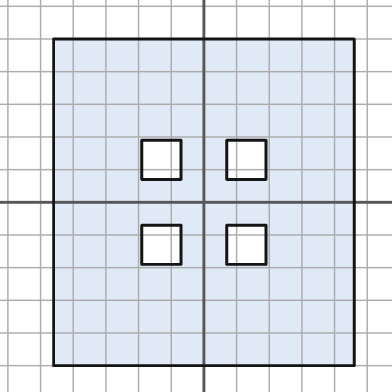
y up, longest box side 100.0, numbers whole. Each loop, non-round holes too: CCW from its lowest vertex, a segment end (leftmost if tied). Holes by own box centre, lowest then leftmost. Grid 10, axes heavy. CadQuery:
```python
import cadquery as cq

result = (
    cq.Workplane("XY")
    .moveTo(-46.0, -50.0)
    .lineTo(46.0, -50.0)
    .lineTo(46.0, 50.0)
    .lineTo(-46.0, 50.0)
    .close()
    .moveTo(-19.0, -19.0)
    .lineTo(-7.0, -19.0)
    .lineTo(-7.0, -7.0)
    .lineTo(-19.0, -7.0)
    .close()
    .moveTo(7.0, -19.0)
    .lineTo(19.0, -19.0)
    .lineTo(19.0, -7.0)
    .lineTo(7.0, -7.0)
    .close()
    .moveTo(-19.0, 7.0)
    .lineTo(-7.0, 7.0)
    .lineTo(-7.0, 19.0)
    .lineTo(-19.0, 19.0)
    .close()
    .moveTo(7.0, 7.0)
    .lineTo(19.0, 7.0)
    .lineTo(19.0, 19.0)
    .lineTo(7.0, 19.0)
    .close()
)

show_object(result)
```